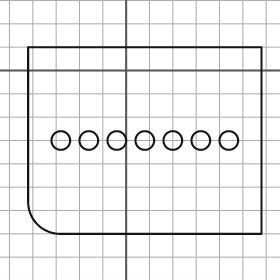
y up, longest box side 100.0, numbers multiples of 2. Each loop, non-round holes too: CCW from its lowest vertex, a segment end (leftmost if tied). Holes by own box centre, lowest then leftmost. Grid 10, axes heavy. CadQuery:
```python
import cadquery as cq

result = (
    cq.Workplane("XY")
    .moveTo(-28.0, -70.0)
    .lineTo(58.0, -70.0)
    .lineTo(58.0, 10.0)
    .lineTo(-42.0, 10.0)
    .lineTo(-42.0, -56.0)
    .threePointArc((-38.0, -66.0), (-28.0, -70.0))
    .close()
    .moveTo(-28.0, -30.0)
    .circle(4.0)
    .moveTo(-16.0, -30.0)
    .circle(4.0)
    .moveTo(-4.0, -30.0)
    .circle(4.0)
    .moveTo(8.0, -30.0)
    .circle(4.0)
    .moveTo(20.0, -30.0)
    .circle(4.0)
    .moveTo(32.0, -30.0)
    .circle(4.0)
    .moveTo(44.0, -30.0)
    .circle(4.0)
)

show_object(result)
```